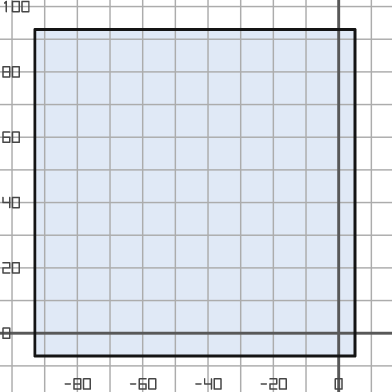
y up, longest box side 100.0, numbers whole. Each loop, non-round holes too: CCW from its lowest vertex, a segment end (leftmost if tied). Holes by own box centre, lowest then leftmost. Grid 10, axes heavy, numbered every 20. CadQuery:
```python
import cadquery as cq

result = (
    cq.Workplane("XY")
    .moveTo(-93.0, -7.0)
    .lineTo(5.0, -7.0)
    .lineTo(5.0, 93.0)
    .lineTo(-93.0, 93.0)
    .close()
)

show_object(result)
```